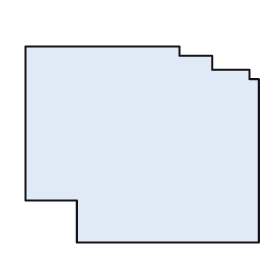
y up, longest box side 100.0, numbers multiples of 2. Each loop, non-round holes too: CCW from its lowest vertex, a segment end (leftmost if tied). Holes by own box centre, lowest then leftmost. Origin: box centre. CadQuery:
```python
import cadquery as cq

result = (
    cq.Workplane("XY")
    .moveTo(-28.0, -42.0)
    .lineTo(50.0, -42.0)
    .lineTo(50.0, 28.0)
    .lineTo(46.0, 28.0)
    .lineTo(46.0, 32.0)
    .lineTo(30.0, 32.0)
    .lineTo(30.0, 38.0)
    .lineTo(16.0, 38.0)
    .lineTo(16.0, 42.0)
    .lineTo(-50.0, 42.0)
    .lineTo(-50.0, -24.0)
    .lineTo(-28.0, -24.0)
    .close()
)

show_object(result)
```